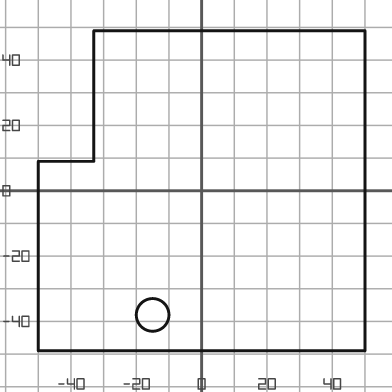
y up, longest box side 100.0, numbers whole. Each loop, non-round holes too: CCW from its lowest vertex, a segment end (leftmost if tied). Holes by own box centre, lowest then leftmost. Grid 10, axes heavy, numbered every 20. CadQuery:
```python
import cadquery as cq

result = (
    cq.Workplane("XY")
    .moveTo(-50.0, -49.0)
    .lineTo(50.0, -49.0)
    .lineTo(50.0, 49.0)
    .lineTo(-33.0, 49.0)
    .lineTo(-33.0, 9.0)
    .lineTo(-50.0, 9.0)
    .close()
    .moveTo(-15.0, -38.0)
    .circle(5.0)
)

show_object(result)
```